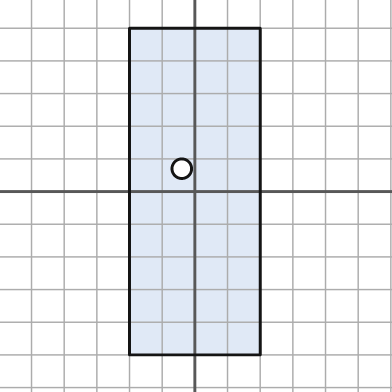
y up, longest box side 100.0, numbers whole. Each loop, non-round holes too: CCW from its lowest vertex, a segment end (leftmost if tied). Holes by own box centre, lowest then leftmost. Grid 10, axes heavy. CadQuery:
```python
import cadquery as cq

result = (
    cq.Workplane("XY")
    .moveTo(-20.0, -50.0)
    .lineTo(20.0, -50.0)
    .lineTo(20.0, 50.0)
    .lineTo(-20.0, 50.0)
    .close()
    .moveTo(-4.0, 7.0)
    .circle(3.0)
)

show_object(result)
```